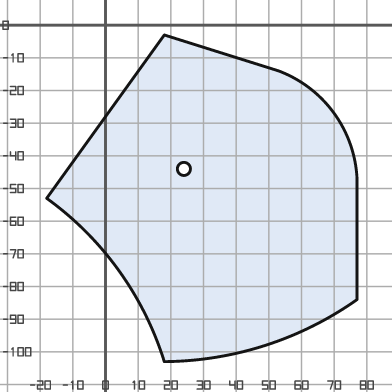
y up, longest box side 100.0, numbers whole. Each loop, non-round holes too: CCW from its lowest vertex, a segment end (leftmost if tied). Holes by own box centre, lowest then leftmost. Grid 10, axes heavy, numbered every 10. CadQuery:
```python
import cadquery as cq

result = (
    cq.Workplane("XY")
    .moveTo(18.0, -103.0)
    .threePointArc((49.0, -98.0), (77.0, -84.0))
    .lineTo(77.0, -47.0)
    .threePointArc((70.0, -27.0), (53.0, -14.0))
    .lineTo(18.0, -3.0)
    .lineTo(-18.0, -53.0)
    .threePointArc((4.0, -75.0), (18.0, -103.0))
    .close()
    .moveTo(24.0, -44.0)
    .circle(2.0)
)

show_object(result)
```